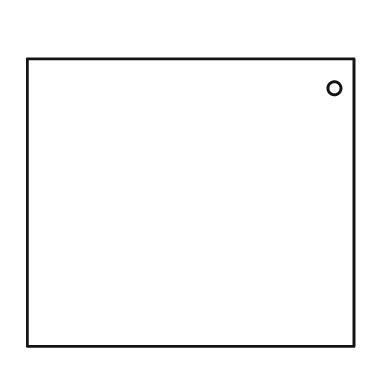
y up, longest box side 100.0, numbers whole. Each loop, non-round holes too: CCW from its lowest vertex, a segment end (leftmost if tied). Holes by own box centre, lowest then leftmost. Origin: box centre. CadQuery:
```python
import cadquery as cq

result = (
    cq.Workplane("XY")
    .moveTo(-50.0, -44.0)
    .lineTo(50.0, -44.0)
    .lineTo(50.0, 44.0)
    .lineTo(-50.0, 44.0)
    .close()
    .moveTo(44.0, 35.0)
    .circle(2.0)
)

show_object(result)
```